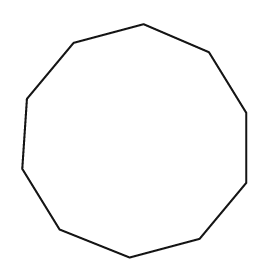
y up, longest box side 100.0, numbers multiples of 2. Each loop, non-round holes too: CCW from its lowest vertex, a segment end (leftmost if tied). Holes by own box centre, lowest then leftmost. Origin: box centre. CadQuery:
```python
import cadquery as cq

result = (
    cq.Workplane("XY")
    .moveTo(-2.0, -50.0)
    .lineTo(28.0, -42.0)
    .lineTo(48.0, -18.0)
    .lineTo(48.0, 12.0)
    .lineTo(32.0, 38.0)
    .lineTo(4.0, 50.0)
    .lineTo(-26.0, 42.0)
    .lineTo(-46.0, 18.0)
    .lineTo(-48.0, -12.0)
    .lineTo(-32.0, -38.0)
    .close()
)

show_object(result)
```